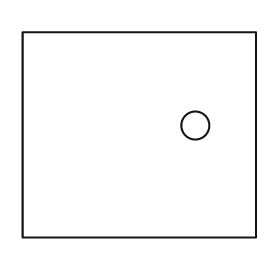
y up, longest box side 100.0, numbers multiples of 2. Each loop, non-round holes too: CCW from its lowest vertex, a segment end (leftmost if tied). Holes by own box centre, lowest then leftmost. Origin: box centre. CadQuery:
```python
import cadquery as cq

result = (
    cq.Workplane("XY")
    .moveTo(-50.0, -44.0)
    .lineTo(50.0, -44.0)
    .lineTo(50.0, 44.0)
    .lineTo(-50.0, 44.0)
    .close()
    .moveTo(24.0, 4.0)
    .circle(6.0)
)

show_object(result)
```